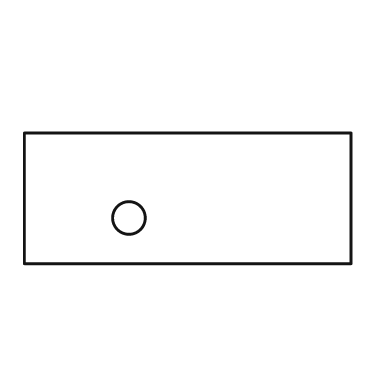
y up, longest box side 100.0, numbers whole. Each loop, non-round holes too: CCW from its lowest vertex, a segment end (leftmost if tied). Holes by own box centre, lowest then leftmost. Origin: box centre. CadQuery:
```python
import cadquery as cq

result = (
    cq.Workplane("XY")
    .moveTo(-50.0, -20.0)
    .lineTo(50.0, -20.0)
    .lineTo(50.0, 20.0)
    .lineTo(-50.0, 20.0)
    .close()
    .moveTo(-18.0, -6.0)
    .circle(5.0)
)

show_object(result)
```